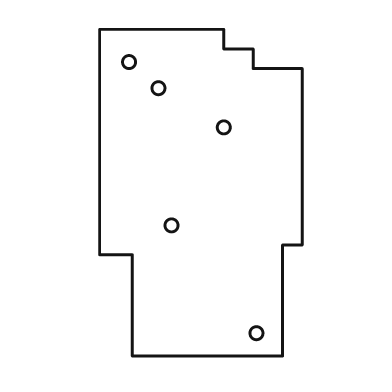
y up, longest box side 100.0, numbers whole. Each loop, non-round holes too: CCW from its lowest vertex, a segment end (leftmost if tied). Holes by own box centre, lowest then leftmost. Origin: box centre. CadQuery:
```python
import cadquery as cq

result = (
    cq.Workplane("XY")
    .moveTo(-21.0, -50.0)
    .lineTo(25.0, -50.0)
    .lineTo(25.0, -16.0)
    .lineTo(31.0, -16.0)
    .lineTo(31.0, 38.0)
    .lineTo(16.0, 38.0)
    .lineTo(16.0, 44.0)
    .lineTo(7.0, 44.0)
    .lineTo(7.0, 50.0)
    .lineTo(-31.0, 50.0)
    .lineTo(-31.0, -19.0)
    .lineTo(-21.0, -19.0)
    .close()
    .moveTo(17.0, -43.0)
    .circle(2.0)
    .moveTo(-9.0, -10.0)
    .circle(2.0)
    .moveTo(7.0, 20.0)
    .circle(2.0)
    .moveTo(-13.0, 32.0)
    .circle(2.0)
    .moveTo(-22.0, 40.0)
    .circle(2.0)
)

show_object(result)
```